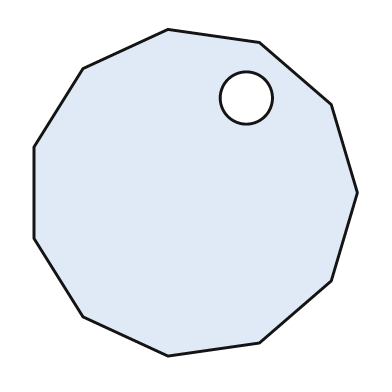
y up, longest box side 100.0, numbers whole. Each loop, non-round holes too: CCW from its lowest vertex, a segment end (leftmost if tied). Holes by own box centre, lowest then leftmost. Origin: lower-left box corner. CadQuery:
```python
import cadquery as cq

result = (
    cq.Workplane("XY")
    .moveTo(41.0, 0.0)
    .lineTo(69.0, 4.0)
    .lineTo(91.0, 23.0)
    .lineTo(99.0, 50.0)
    .lineTo(91.0, 77.0)
    .lineTo(69.0, 96.0)
    .lineTo(41.0, 100.0)
    .lineTo(15.0, 88.0)
    .lineTo(0.0, 64.0)
    .lineTo(0.0, 36.0)
    .lineTo(15.0, 12.0)
    .close()
    .moveTo(65.0, 79.0)
    .circle(8.0)
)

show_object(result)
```